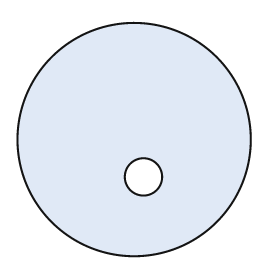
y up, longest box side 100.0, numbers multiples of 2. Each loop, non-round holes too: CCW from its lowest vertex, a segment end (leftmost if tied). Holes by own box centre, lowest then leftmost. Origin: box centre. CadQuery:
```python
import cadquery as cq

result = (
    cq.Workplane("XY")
    .moveTo(0.0, 0.0)
    .circle(50.0)
    .moveTo(4.0, -16.0)
    .circle(8.0)
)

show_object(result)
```